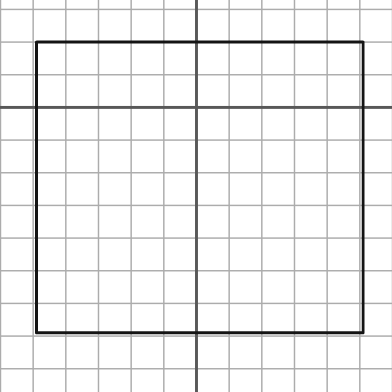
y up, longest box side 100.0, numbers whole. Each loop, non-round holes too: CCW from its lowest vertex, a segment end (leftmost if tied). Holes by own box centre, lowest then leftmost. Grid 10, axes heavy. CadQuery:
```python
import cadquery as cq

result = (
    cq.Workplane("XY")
    .moveTo(-49.0, -69.0)
    .lineTo(51.0, -69.0)
    .lineTo(51.0, 20.0)
    .lineTo(-49.0, 20.0)
    .close()
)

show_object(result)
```